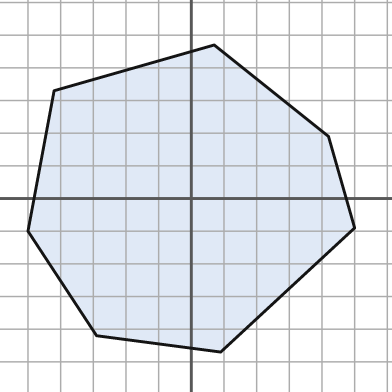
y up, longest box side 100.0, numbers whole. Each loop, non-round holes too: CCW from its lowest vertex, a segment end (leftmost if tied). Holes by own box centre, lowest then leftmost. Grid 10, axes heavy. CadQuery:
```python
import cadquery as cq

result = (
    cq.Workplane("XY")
    .moveTo(9.0, -47.0)
    .lineTo(50.0, -9.0)
    .lineTo(42.0, 19.0)
    .lineTo(7.0, 47.0)
    .lineTo(-42.0, 33.0)
    .lineTo(-50.0, -10.0)
    .lineTo(-29.0, -42.0)
    .close()
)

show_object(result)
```